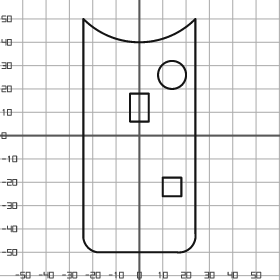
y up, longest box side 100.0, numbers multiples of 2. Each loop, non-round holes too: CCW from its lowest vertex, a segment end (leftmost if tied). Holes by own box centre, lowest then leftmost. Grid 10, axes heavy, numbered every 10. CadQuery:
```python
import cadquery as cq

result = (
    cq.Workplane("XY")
    .moveTo(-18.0, -50.0)
    .lineTo(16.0, -50.0)
    .threePointArc((22.0, -48.0), (24.0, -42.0))
    .lineTo(24.0, 50.0)
    .threePointArc((0.0, 40.0), (-24.0, 50.0))
    .lineTo(-24.0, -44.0)
    .threePointArc((-22.0, -48.0), (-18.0, -50.0))
    .close()
    .moveTo(10.0, -26.0)
    .lineTo(18.0, -26.0)
    .lineTo(18.0, -18.0)
    .lineTo(10.0, -18.0)
    .close()
    .moveTo(-4.0, 6.0)
    .lineTo(4.0, 6.0)
    .lineTo(4.0, 18.0)
    .lineTo(-4.0, 18.0)
    .close()
    .moveTo(14.0, 26.0)
    .circle(6.0)
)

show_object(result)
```